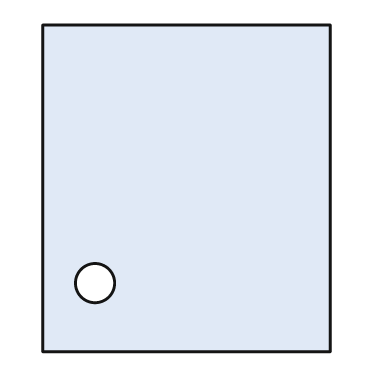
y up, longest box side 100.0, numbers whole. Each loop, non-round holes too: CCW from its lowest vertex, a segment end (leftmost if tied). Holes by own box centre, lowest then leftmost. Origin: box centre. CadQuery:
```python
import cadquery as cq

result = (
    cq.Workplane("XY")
    .moveTo(-44.0, -50.0)
    .lineTo(44.0, -50.0)
    .lineTo(44.0, 50.0)
    .lineTo(-44.0, 50.0)
    .close()
    .moveTo(-28.0, -29.0)
    .circle(6.0)
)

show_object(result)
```